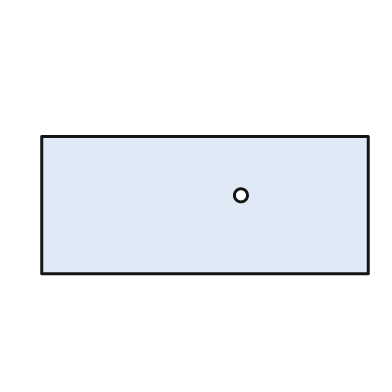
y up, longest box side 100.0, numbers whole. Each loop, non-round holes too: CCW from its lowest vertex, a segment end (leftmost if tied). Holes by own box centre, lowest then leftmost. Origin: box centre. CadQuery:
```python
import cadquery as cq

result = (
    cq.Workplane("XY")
    .moveTo(-50.0, -21.0)
    .lineTo(50.0, -21.0)
    .lineTo(50.0, 21.0)
    .lineTo(-50.0, 21.0)
    .close()
    .moveTo(11.0, 3.0)
    .circle(2.0)
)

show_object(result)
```